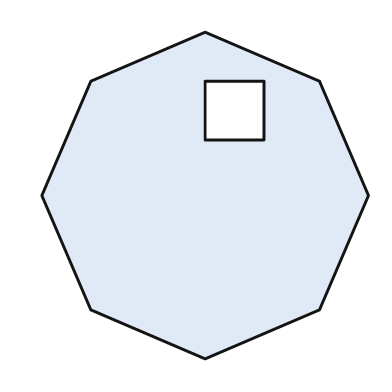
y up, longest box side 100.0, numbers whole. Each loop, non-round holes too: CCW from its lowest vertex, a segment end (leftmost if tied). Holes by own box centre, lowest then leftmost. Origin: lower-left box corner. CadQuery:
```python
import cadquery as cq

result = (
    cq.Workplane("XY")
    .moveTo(50.0, 0.0)
    .lineTo(85.0, 15.0)
    .lineTo(100.0, 50.0)
    .lineTo(85.0, 85.0)
    .lineTo(50.0, 100.0)
    .lineTo(15.0, 85.0)
    .lineTo(0.0, 50.0)
    .lineTo(15.0, 15.0)
    .close()
    .moveTo(50.0, 67.0)
    .lineTo(68.0, 67.0)
    .lineTo(68.0, 85.0)
    .lineTo(50.0, 85.0)
    .close()
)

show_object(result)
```